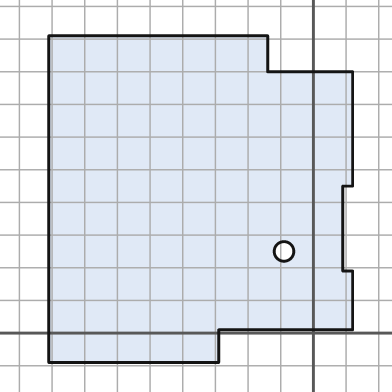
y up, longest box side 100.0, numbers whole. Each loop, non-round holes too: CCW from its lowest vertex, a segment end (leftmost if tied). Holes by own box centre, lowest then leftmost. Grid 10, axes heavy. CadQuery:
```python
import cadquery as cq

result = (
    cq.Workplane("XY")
    .moveTo(-81.0, -9.0)
    .lineTo(-29.0, -9.0)
    .lineTo(-29.0, 1.0)
    .lineTo(12.0, 1.0)
    .lineTo(12.0, 19.0)
    .lineTo(9.0, 19.0)
    .lineTo(9.0, 45.0)
    .lineTo(12.0, 45.0)
    .lineTo(12.0, 80.0)
    .lineTo(-14.0, 80.0)
    .lineTo(-14.0, 91.0)
    .lineTo(-81.0, 91.0)
    .close()
    .moveTo(-9.0, 25.0)
    .circle(3.0)
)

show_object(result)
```